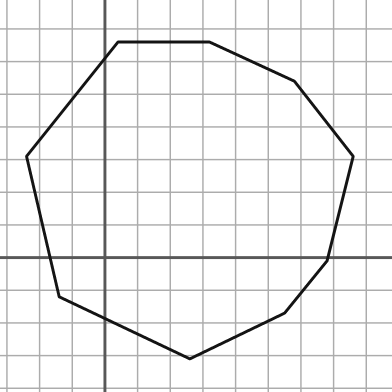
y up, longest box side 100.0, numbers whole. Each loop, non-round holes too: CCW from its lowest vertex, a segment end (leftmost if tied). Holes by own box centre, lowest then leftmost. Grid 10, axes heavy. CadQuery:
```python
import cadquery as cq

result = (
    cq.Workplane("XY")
    .moveTo(26.0, -31.0)
    .lineTo(55.0, -17.0)
    .lineTo(68.0, -1.0)
    .lineTo(76.0, 31.0)
    .lineTo(58.0, 54.0)
    .lineTo(32.0, 66.0)
    .lineTo(4.0, 66.0)
    .lineTo(-24.0, 31.0)
    .lineTo(-14.0, -12.0)
    .close()
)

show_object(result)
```